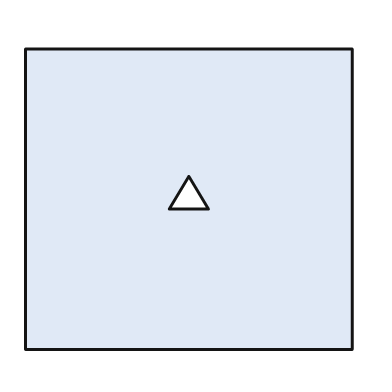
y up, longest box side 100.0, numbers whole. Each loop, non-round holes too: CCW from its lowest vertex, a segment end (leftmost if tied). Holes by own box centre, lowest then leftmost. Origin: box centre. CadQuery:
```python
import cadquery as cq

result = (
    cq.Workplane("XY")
    .moveTo(-50.0, -46.0)
    .lineTo(50.0, -46.0)
    .lineTo(50.0, 46.0)
    .lineTo(-50.0, 46.0)
    .close()
    .moveTo(-6.0, -3.0)
    .lineTo(6.0, -3.0)
    .lineTo(0.0, 7.0)
    .close()
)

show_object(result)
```